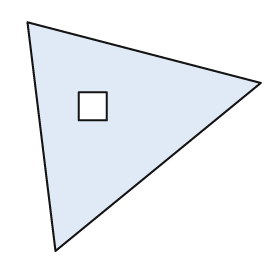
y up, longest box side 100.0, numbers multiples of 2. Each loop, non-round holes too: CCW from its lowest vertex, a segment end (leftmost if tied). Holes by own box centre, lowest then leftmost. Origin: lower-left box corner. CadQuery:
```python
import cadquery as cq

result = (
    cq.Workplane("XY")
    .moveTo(12.0, 0.0)
    .lineTo(100.0, 72.0)
    .lineTo(0.0, 98.0)
    .close()
    .moveTo(22.0, 56.0)
    .lineTo(34.0, 56.0)
    .lineTo(34.0, 68.0)
    .lineTo(22.0, 68.0)
    .close()
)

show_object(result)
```